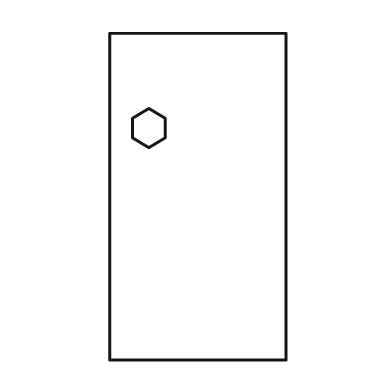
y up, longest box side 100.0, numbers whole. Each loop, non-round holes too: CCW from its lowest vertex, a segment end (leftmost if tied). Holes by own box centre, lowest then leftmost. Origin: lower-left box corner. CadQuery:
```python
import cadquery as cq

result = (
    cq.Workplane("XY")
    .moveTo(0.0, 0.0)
    .lineTo(54.0, 0.0)
    .lineTo(54.0, 100.0)
    .lineTo(0.0, 100.0)
    .close()
    .moveTo(12.0, 65.0)
    .lineTo(17.0, 68.0)
    .lineTo(17.0, 74.0)
    .lineTo(12.0, 77.0)
    .lineTo(7.0, 74.0)
    .lineTo(7.0, 68.0)
    .close()
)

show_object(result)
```